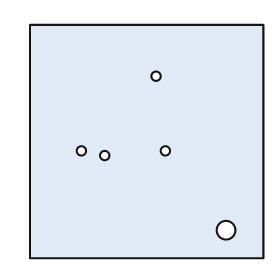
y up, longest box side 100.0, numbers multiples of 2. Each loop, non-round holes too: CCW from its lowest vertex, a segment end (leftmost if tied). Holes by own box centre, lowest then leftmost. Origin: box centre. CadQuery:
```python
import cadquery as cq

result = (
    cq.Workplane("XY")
    .moveTo(-50.0, -50.0)
    .lineTo(50.0, -50.0)
    .lineTo(50.0, 50.0)
    .lineTo(-50.0, 50.0)
    .close()
    .moveTo(34.0, -38.0)
    .circle(4.0)
    .moveTo(-18.0, -6.0)
    .circle(2.0)
    .moveTo(-28.0, -4.0)
    .circle(2.0)
    .moveTo(8.0, -4.0)
    .circle(2.0)
    .moveTo(4.0, 28.0)
    .circle(2.0)
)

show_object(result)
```